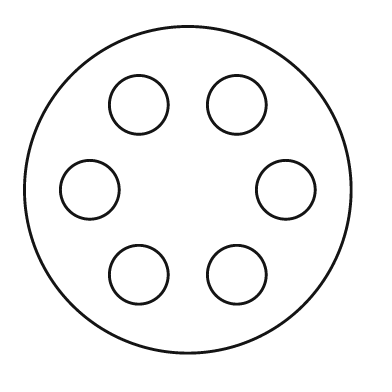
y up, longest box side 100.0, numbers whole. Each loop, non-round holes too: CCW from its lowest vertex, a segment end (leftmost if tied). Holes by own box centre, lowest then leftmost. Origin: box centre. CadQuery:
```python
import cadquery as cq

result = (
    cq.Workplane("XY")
    .moveTo(0.0, 0.0)
    .circle(50.0)
    .moveTo(-15.0, -26.0)
    .circle(9.0)
    .moveTo(15.0, -26.0)
    .circle(9.0)
    .moveTo(-30.0, 0.0)
    .circle(9.0)
    .moveTo(30.0, 0.0)
    .circle(9.0)
    .moveTo(-15.0, 26.0)
    .circle(9.0)
    .moveTo(15.0, 26.0)
    .circle(9.0)
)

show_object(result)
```